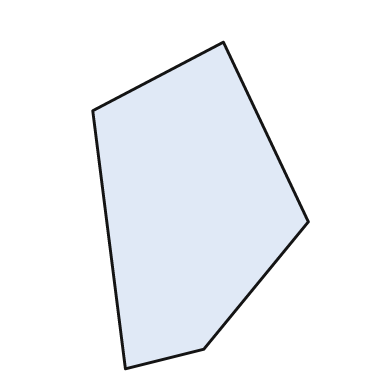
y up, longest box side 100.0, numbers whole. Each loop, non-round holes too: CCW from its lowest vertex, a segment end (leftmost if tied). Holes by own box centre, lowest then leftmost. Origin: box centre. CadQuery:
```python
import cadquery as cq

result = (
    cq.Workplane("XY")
    .moveTo(-23.0, -50.0)
    .lineTo(1.0, -44.0)
    .lineTo(33.0, -5.0)
    .lineTo(7.0, 50.0)
    .lineTo(-33.0, 29.0)
    .close()
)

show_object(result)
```